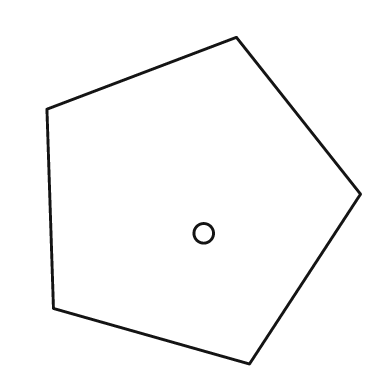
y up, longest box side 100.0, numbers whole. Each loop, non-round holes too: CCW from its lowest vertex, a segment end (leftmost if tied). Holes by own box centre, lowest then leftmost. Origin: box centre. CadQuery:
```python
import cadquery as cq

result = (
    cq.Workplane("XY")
    .moveTo(14.0, -50.0)
    .lineTo(48.0, 2.0)
    .lineTo(10.0, 50.0)
    .lineTo(-48.0, 28.0)
    .lineTo(-46.0, -33.0)
    .close()
    .moveTo(0.0, -10.0)
    .circle(3.0)
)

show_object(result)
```